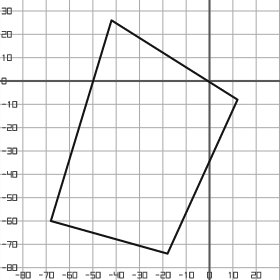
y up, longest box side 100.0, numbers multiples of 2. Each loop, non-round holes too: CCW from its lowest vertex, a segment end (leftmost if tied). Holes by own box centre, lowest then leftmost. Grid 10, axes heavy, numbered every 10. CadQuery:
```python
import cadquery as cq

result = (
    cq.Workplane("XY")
    .moveTo(-18.0, -74.0)
    .lineTo(12.0, -8.0)
    .lineTo(-42.0, 26.0)
    .lineTo(-68.0, -60.0)
    .close()
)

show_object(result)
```